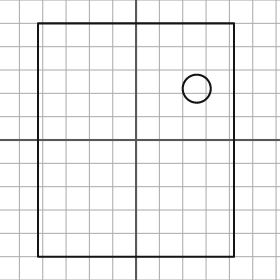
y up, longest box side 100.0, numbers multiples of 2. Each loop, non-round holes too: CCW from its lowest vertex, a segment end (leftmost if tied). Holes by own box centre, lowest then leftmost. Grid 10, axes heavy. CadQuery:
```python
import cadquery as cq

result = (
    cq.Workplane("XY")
    .moveTo(-42.0, -50.0)
    .lineTo(42.0, -50.0)
    .lineTo(42.0, 50.0)
    .lineTo(-42.0, 50.0)
    .close()
    .moveTo(26.0, 22.0)
    .circle(6.0)
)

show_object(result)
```